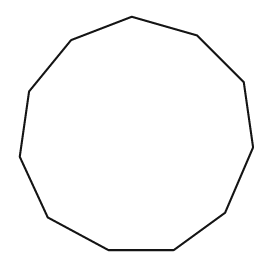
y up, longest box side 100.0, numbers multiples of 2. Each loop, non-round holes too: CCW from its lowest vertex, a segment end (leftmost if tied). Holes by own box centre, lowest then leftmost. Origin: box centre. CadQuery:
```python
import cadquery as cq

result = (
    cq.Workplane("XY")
    .moveTo(-12.0, -50.0)
    .lineTo(16.0, -50.0)
    .lineTo(38.0, -34.0)
    .lineTo(50.0, -6.0)
    .lineTo(46.0, 22.0)
    .lineTo(26.0, 42.0)
    .lineTo(-2.0, 50.0)
    .lineTo(-28.0, 40.0)
    .lineTo(-46.0, 18.0)
    .lineTo(-50.0, -10.0)
    .lineTo(-38.0, -36.0)
    .close()
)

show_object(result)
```